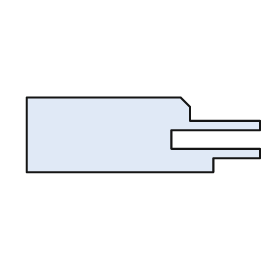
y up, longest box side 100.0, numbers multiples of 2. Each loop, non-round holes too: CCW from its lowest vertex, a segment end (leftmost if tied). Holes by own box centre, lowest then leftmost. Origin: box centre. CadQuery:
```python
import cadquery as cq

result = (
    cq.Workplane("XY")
    .moveTo(-50.0, -16.0)
    .lineTo(30.0, -16.0)
    .lineTo(30.0, -10.0)
    .lineTo(50.0, -10.0)
    .lineTo(50.0, -6.0)
    .lineTo(12.0, -6.0)
    .lineTo(12.0, 2.0)
    .lineTo(50.0, 2.0)
    .lineTo(50.0, 6.0)
    .lineTo(20.0, 6.0)
    .lineTo(20.0, 12.0)
    .lineTo(16.0, 16.0)
    .lineTo(-50.0, 16.0)
    .close()
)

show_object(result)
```